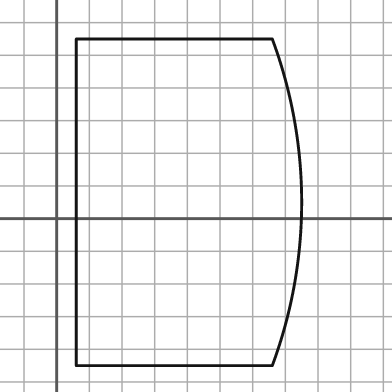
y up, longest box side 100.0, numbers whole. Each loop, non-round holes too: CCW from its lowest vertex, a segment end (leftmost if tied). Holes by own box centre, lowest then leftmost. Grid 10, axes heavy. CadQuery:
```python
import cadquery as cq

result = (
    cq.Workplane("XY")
    .moveTo(6.0, -45.0)
    .lineTo(66.0, -45.0)
    .threePointArc((75.0, 5.0), (66.0, 55.0))
    .lineTo(6.0, 55.0)
    .close()
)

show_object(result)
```